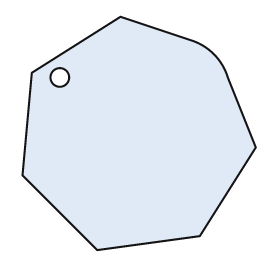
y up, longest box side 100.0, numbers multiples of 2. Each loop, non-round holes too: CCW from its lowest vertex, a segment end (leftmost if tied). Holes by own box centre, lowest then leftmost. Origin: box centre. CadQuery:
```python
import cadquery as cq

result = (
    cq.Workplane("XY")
    .moveTo(-18.0, -50.0)
    .lineTo(26.0, -44.0)
    .lineTo(50.0, -6.0)
    .lineTo(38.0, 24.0)
    .threePointArc((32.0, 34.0), (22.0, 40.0))
    .lineTo(-8.0, 50.0)
    .lineTo(-46.0, 26.0)
    .lineTo(-50.0, -18.0)
    .close()
    .moveTo(-34.0, 24.0)
    .circle(4.0)
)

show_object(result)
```